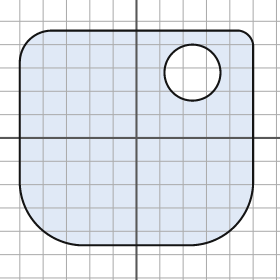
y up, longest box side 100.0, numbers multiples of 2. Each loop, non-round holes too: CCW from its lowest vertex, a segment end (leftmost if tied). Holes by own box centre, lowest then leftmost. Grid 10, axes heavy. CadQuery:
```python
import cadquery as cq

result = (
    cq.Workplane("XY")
    .moveTo(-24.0, -46.0)
    .lineTo(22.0, -46.0)
    .threePointArc((42.0, -38.0), (50.0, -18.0))
    .lineTo(50.0, 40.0)
    .threePointArc((48.0, 44.0), (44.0, 46.0))
    .lineTo(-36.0, 46.0)
    .threePointArc((-46.0, 42.0), (-50.0, 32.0))
    .lineTo(-50.0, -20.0)
    .threePointArc((-42.0, -38.0), (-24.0, -46.0))
    .close()
    .moveTo(24.0, 28.0)
    .circle(12.0)
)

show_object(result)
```